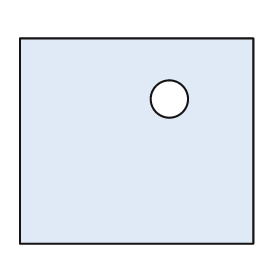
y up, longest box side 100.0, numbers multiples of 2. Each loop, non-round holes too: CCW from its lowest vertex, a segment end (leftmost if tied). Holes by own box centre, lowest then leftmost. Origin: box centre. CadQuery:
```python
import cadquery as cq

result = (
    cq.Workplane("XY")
    .moveTo(-50.0, -44.0)
    .lineTo(50.0, -44.0)
    .lineTo(50.0, 44.0)
    .lineTo(-50.0, 44.0)
    .close()
    .moveTo(14.0, 18.0)
    .circle(8.0)
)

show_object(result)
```